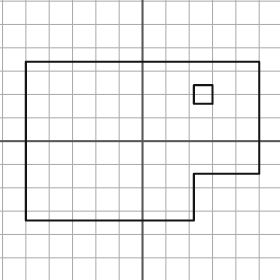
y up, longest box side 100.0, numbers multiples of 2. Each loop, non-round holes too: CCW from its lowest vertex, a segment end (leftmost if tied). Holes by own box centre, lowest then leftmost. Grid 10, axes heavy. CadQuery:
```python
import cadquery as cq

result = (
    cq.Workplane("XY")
    .moveTo(-50.0, -34.0)
    .lineTo(22.0, -34.0)
    .lineTo(22.0, -14.0)
    .lineTo(50.0, -14.0)
    .lineTo(50.0, 34.0)
    .lineTo(-50.0, 34.0)
    .close()
    .moveTo(22.0, 16.0)
    .lineTo(30.0, 16.0)
    .lineTo(30.0, 24.0)
    .lineTo(22.0, 24.0)
    .close()
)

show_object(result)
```